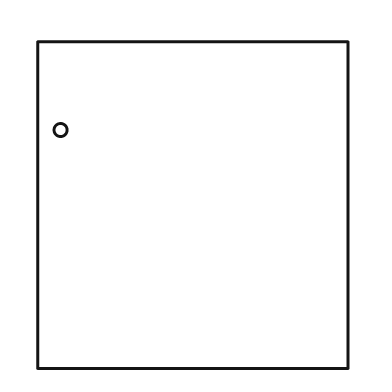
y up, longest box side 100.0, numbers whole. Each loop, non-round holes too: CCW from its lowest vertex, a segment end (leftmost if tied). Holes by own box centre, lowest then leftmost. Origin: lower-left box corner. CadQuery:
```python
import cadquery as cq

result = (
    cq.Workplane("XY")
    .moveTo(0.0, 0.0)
    .lineTo(95.0, 0.0)
    .lineTo(95.0, 100.0)
    .lineTo(0.0, 100.0)
    .close()
    .moveTo(7.0, 73.0)
    .circle(2.0)
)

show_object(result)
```